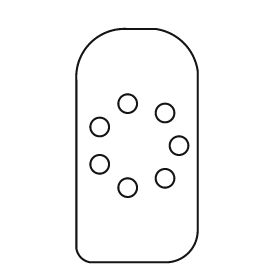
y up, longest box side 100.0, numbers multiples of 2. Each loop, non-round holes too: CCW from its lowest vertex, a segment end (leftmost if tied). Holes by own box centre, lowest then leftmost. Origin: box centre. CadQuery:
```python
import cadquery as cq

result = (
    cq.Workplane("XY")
    .moveTo(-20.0, -50.0)
    .lineTo(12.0, -50.0)
    .threePointArc((22.0, -46.0), (26.0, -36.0))
    .lineTo(26.0, 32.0)
    .threePointArc((20.0, 44.0), (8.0, 50.0))
    .lineTo(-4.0, 50.0)
    .threePointArc((-20.0, 44.0), (-26.0, 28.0))
    .lineTo(-26.0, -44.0)
    .threePointArc((-24.0, -48.0), (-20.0, -50.0))
    .close()
    .moveTo(-4.0, -18.0)
    .circle(4.0)
    .moveTo(12.0, -14.0)
    .circle(4.0)
    .moveTo(-16.0, -8.0)
    .circle(4.0)
    .moveTo(18.0, 0.0)
    .circle(4.0)
    .moveTo(-16.0, 8.0)
    .circle(4.0)
    .moveTo(12.0, 14.0)
    .circle(4.0)
    .moveTo(-4.0, 18.0)
    .circle(4.0)
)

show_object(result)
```